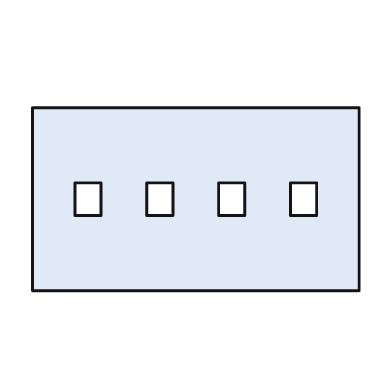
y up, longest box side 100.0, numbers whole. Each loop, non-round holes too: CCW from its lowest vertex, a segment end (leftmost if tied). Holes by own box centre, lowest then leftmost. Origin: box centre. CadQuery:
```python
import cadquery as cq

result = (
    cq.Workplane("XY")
    .moveTo(-50.0, -28.0)
    .lineTo(50.0, -28.0)
    .lineTo(50.0, 28.0)
    .lineTo(-50.0, 28.0)
    .close()
    .moveTo(-37.0, -5.0)
    .lineTo(-29.0, -5.0)
    .lineTo(-29.0, 5.0)
    .lineTo(-37.0, 5.0)
    .close()
    .moveTo(-15.0, -5.0)
    .lineTo(-7.0, -5.0)
    .lineTo(-7.0, 5.0)
    .lineTo(-15.0, 5.0)
    .close()
    .moveTo(7.0, -5.0)
    .lineTo(15.0, -5.0)
    .lineTo(15.0, 5.0)
    .lineTo(7.0, 5.0)
    .close()
    .moveTo(29.0, -5.0)
    .lineTo(37.0, -5.0)
    .lineTo(37.0, 5.0)
    .lineTo(29.0, 5.0)
    .close()
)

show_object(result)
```